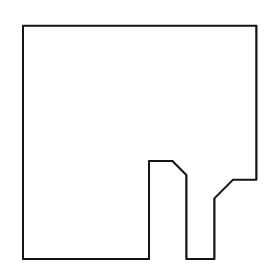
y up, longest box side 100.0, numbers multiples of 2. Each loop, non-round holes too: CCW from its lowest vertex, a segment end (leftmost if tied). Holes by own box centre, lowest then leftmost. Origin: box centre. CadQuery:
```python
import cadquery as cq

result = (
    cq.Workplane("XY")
    .moveTo(-50.0, -50.0)
    .lineTo(4.0, -50.0)
    .lineTo(4.0, -8.0)
    .lineTo(14.0, -8.0)
    .lineTo(20.0, -14.0)
    .lineTo(20.0, -50.0)
    .lineTo(32.0, -50.0)
    .lineTo(32.0, -24.0)
    .lineTo(40.0, -16.0)
    .lineTo(50.0, -16.0)
    .lineTo(50.0, 50.0)
    .lineTo(-50.0, 50.0)
    .close()
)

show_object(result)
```